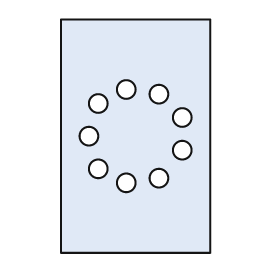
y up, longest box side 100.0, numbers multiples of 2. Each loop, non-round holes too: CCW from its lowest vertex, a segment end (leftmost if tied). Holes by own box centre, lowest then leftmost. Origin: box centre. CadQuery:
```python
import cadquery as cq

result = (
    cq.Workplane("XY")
    .moveTo(-32.0, -50.0)
    .lineTo(32.0, -50.0)
    .lineTo(32.0, 50.0)
    .lineTo(-32.0, 50.0)
    .close()
    .moveTo(-4.0, -20.0)
    .circle(4.0)
    .moveTo(10.0, -18.0)
    .circle(4.0)
    .moveTo(-16.0, -14.0)
    .circle(4.0)
    .moveTo(20.0, -6.0)
    .circle(4.0)
    .moveTo(-20.0, 0.0)
    .circle(4.0)
    .moveTo(20.0, 8.0)
    .circle(4.0)
    .moveTo(-16.0, 14.0)
    .circle(4.0)
    .moveTo(10.0, 18.0)
    .circle(4.0)
    .moveTo(-4.0, 20.0)
    .circle(4.0)
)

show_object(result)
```